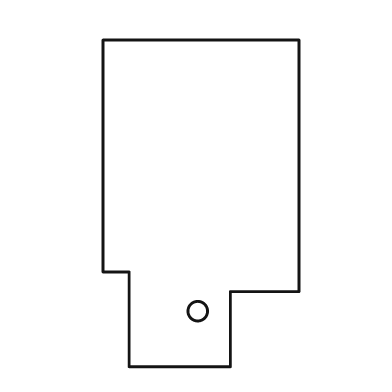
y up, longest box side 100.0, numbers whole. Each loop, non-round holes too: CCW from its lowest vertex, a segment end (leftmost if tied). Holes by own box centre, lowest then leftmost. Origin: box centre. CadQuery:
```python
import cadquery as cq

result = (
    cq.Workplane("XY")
    .moveTo(-22.0, -50.0)
    .lineTo(9.0, -50.0)
    .lineTo(9.0, -27.0)
    .lineTo(30.0, -27.0)
    .lineTo(30.0, 50.0)
    .lineTo(-30.0, 50.0)
    .lineTo(-30.0, -21.0)
    .lineTo(-22.0, -21.0)
    .close()
    .moveTo(-1.0, -33.0)
    .circle(3.0)
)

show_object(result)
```